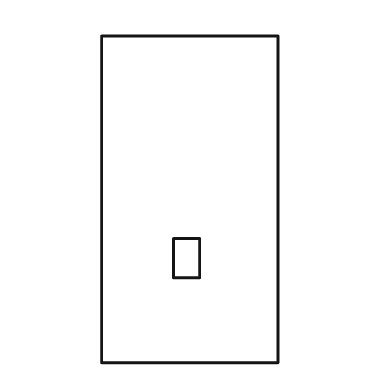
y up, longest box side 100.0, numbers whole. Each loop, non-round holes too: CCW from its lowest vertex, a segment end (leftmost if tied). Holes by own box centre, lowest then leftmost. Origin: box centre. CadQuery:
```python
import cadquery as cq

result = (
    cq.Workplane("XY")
    .moveTo(-27.0, -50.0)
    .lineTo(27.0, -50.0)
    .lineTo(27.0, 50.0)
    .lineTo(-27.0, 50.0)
    .close()
    .moveTo(-5.0, -24.0)
    .lineTo(3.0, -24.0)
    .lineTo(3.0, -12.0)
    .lineTo(-5.0, -12.0)
    .close()
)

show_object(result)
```